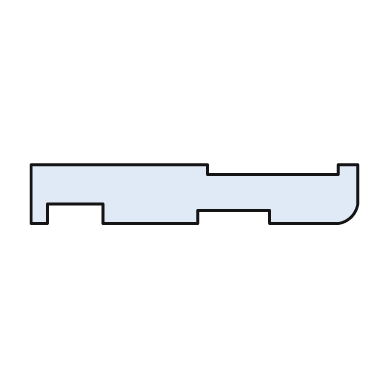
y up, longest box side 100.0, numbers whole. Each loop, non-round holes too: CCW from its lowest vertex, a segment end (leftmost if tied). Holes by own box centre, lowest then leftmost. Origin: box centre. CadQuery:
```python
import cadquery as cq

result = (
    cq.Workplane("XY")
    .moveTo(-50.0, -9.0)
    .lineTo(-45.0, -9.0)
    .lineTo(-45.0, -3.0)
    .lineTo(-28.0, -3.0)
    .lineTo(-28.0, -9.0)
    .lineTo(1.0, -9.0)
    .lineTo(1.0, -5.0)
    .lineTo(23.0, -5.0)
    .lineTo(23.0, -9.0)
    .lineTo(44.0, -9.0)
    .threePointArc((48.0, -7.0), (50.0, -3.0))
    .lineTo(50.0, 9.0)
    .lineTo(44.0, 9.0)
    .lineTo(44.0, 6.0)
    .lineTo(4.0, 6.0)
    .lineTo(4.0, 9.0)
    .lineTo(-50.0, 9.0)
    .close()
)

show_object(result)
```